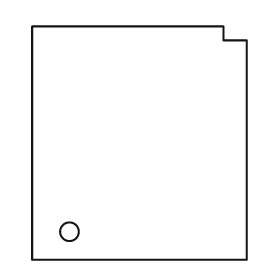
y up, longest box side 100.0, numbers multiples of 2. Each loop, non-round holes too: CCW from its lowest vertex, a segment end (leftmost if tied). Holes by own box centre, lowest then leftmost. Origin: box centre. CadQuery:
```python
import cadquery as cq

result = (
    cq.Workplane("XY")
    .moveTo(-46.0, -50.0)
    .lineTo(46.0, -50.0)
    .lineTo(46.0, 44.0)
    .lineTo(36.0, 44.0)
    .lineTo(36.0, 50.0)
    .lineTo(-46.0, 50.0)
    .close()
    .moveTo(-30.0, -38.0)
    .circle(4.0)
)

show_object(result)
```